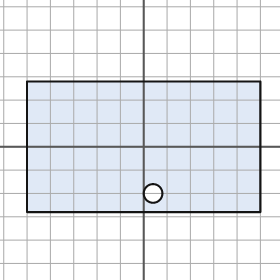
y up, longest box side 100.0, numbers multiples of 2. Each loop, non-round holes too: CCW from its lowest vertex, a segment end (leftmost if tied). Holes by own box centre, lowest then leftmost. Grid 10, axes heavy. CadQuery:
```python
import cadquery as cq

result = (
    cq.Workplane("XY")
    .moveTo(-50.0, -28.0)
    .lineTo(50.0, -28.0)
    .lineTo(50.0, 28.0)
    .lineTo(-50.0, 28.0)
    .close()
    .moveTo(4.0, -20.0)
    .circle(4.0)
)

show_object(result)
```